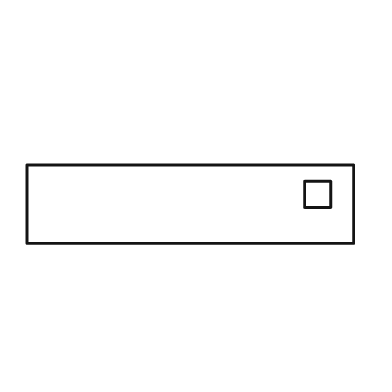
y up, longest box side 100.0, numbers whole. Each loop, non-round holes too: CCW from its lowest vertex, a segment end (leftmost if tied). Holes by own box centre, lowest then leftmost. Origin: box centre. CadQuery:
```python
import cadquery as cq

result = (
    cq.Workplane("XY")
    .moveTo(-50.0, -12.0)
    .lineTo(50.0, -12.0)
    .lineTo(50.0, 12.0)
    .lineTo(-50.0, 12.0)
    .close()
    .moveTo(35.0, -1.0)
    .lineTo(43.0, -1.0)
    .lineTo(43.0, 7.0)
    .lineTo(35.0, 7.0)
    .close()
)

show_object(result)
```